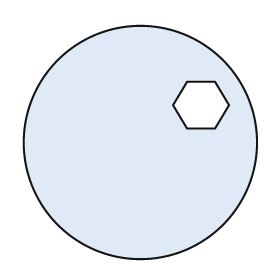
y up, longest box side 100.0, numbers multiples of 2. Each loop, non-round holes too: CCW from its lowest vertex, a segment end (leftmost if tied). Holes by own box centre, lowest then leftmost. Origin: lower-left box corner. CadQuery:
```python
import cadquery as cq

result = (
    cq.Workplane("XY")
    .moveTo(50.0, 50.0)
    .circle(50.0)
    .moveTo(70.0, 56.0)
    .lineTo(82.0, 56.0)
    .lineTo(88.0, 66.0)
    .lineTo(82.0, 76.0)
    .lineTo(70.0, 76.0)
    .lineTo(64.0, 66.0)
    .close()
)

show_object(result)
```